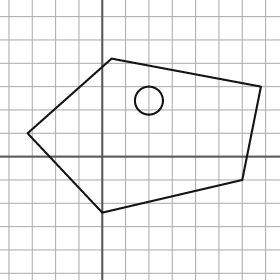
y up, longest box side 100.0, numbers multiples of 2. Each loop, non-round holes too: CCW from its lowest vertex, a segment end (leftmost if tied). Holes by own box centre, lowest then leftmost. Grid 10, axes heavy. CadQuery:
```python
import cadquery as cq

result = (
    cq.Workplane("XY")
    .moveTo(0.0, -24.0)
    .lineTo(60.0, -10.0)
    .lineTo(68.0, 30.0)
    .lineTo(4.0, 42.0)
    .lineTo(-32.0, 10.0)
    .close()
    .moveTo(20.0, 24.0)
    .circle(6.0)
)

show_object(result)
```